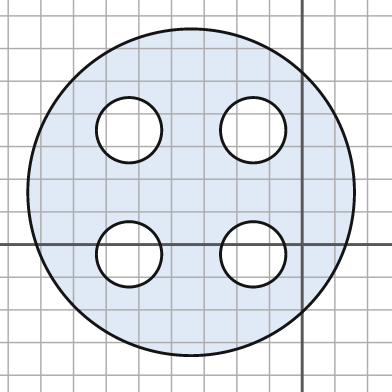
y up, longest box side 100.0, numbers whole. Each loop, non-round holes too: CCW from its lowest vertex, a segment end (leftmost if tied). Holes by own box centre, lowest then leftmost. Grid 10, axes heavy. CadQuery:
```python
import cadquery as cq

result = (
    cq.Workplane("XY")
    .moveTo(-34.0, 16.0)
    .circle(50.0)
    .moveTo(-53.0, -3.0)
    .circle(10.0)
    .moveTo(-15.0, -3.0)
    .circle(10.0)
    .moveTo(-53.0, 35.0)
    .circle(10.0)
    .moveTo(-15.0, 35.0)
    .circle(10.0)
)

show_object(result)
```